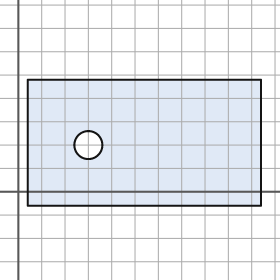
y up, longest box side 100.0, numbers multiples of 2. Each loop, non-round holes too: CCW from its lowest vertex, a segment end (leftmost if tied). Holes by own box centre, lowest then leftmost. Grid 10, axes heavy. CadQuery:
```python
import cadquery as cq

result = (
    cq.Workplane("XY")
    .moveTo(4.0, -6.0)
    .lineTo(104.0, -6.0)
    .lineTo(104.0, 48.0)
    .lineTo(4.0, 48.0)
    .close()
    .moveTo(30.0, 20.0)
    .circle(6.0)
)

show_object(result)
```